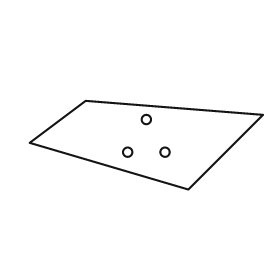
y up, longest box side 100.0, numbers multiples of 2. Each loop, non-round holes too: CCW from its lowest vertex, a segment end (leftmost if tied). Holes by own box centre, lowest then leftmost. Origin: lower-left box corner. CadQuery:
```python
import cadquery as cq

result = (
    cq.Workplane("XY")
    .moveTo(68.0, 0.0)
    .lineTo(100.0, 32.0)
    .lineTo(24.0, 38.0)
    .lineTo(0.0, 20.0)
    .close()
    .moveTo(42.0, 16.0)
    .circle(2.0)
    .moveTo(58.0, 16.0)
    .circle(2.0)
    .moveTo(50.0, 30.0)
    .circle(2.0)
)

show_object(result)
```